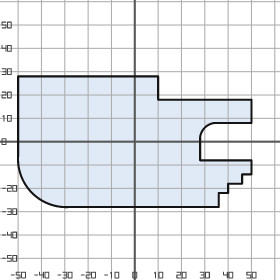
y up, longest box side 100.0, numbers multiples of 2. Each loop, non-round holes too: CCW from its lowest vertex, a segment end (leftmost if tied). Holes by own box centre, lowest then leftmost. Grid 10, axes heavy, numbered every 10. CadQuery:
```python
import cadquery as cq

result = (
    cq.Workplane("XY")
    .moveTo(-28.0, -28.0)
    .lineTo(36.0, -28.0)
    .lineTo(36.0, -22.0)
    .lineTo(40.0, -22.0)
    .lineTo(40.0, -18.0)
    .lineTo(46.0, -18.0)
    .lineTo(46.0, -14.0)
    .lineTo(50.0, -14.0)
    .lineTo(50.0, -8.0)
    .lineTo(28.0, -8.0)
    .lineTo(28.0, 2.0)
    .threePointArc((30.0, 6.0), (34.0, 8.0))
    .lineTo(50.0, 8.0)
    .lineTo(50.0, 18.0)
    .lineTo(10.0, 18.0)
    .lineTo(10.0, 28.0)
    .lineTo(-50.0, 28.0)
    .lineTo(-50.0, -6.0)
    .threePointArc((-44.0, -22.0), (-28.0, -28.0))
    .close()
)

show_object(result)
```